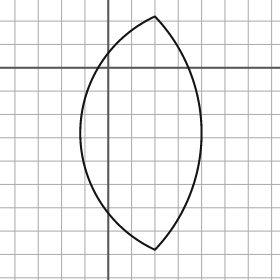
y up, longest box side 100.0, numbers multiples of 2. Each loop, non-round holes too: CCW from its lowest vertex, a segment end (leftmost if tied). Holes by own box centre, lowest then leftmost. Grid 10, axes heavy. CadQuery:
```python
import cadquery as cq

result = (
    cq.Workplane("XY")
    .moveTo(20.0, -78.0)
    .threePointArc((40.0, -28.0), (20.0, 22.0))
    .threePointArc((-12.0, -28.0), (20.0, -78.0))
    .close()
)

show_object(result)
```